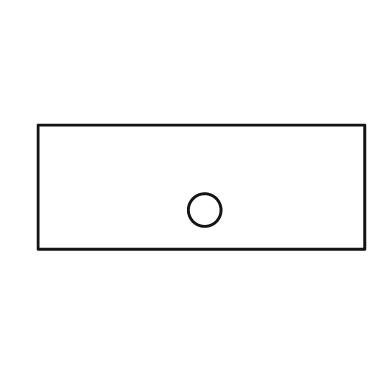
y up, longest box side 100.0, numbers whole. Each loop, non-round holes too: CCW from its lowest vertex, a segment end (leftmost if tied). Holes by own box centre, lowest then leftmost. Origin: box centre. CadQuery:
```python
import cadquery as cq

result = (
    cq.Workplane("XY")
    .moveTo(-50.0, -19.0)
    .lineTo(50.0, -19.0)
    .lineTo(50.0, 19.0)
    .lineTo(-50.0, 19.0)
    .close()
    .moveTo(1.0, -7.0)
    .circle(5.0)
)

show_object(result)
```